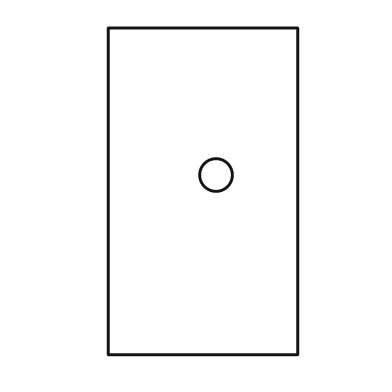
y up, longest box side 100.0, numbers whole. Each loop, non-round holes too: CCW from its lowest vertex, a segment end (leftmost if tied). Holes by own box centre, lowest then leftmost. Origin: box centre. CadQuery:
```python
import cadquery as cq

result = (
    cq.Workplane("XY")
    .moveTo(-29.0, -50.0)
    .lineTo(29.0, -50.0)
    .lineTo(29.0, 50.0)
    .lineTo(-29.0, 50.0)
    .close()
    .moveTo(4.0, 5.0)
    .circle(5.0)
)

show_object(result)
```